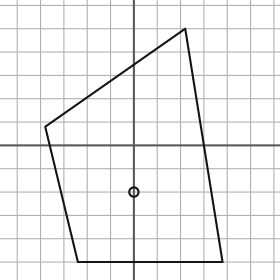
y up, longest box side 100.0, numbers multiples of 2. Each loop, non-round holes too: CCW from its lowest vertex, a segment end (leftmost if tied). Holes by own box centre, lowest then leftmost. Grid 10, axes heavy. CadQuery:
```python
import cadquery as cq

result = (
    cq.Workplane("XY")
    .moveTo(-24.0, -50.0)
    .lineTo(38.0, -50.0)
    .lineTo(22.0, 50.0)
    .lineTo(-38.0, 8.0)
    .close()
    .moveTo(0.0, -20.0)
    .circle(2.0)
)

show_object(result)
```